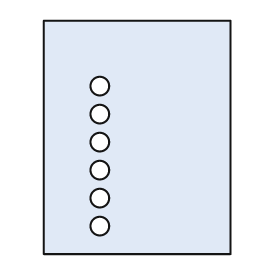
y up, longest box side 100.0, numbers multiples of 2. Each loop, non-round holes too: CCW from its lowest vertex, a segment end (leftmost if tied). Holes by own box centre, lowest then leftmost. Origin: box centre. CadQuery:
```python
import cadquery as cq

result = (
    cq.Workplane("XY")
    .moveTo(-40.0, -50.0)
    .lineTo(40.0, -50.0)
    .lineTo(40.0, 50.0)
    .lineTo(-40.0, 50.0)
    .close()
    .moveTo(-16.0, -38.0)
    .circle(4.0)
    .moveTo(-16.0, -26.0)
    .circle(4.0)
    .moveTo(-16.0, -14.0)
    .circle(4.0)
    .moveTo(-16.0, -2.0)
    .circle(4.0)
    .moveTo(-16.0, 10.0)
    .circle(4.0)
    .moveTo(-16.0, 22.0)
    .circle(4.0)
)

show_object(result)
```